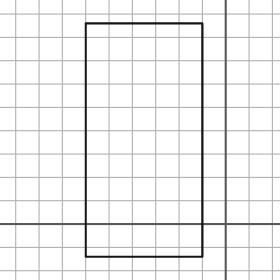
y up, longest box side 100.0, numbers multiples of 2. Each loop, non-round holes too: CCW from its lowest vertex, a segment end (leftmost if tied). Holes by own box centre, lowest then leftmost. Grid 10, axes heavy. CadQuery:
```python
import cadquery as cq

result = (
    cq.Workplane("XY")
    .moveTo(-60.0, -14.0)
    .lineTo(-10.0, -14.0)
    .lineTo(-10.0, 86.0)
    .lineTo(-60.0, 86.0)
    .close()
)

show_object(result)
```